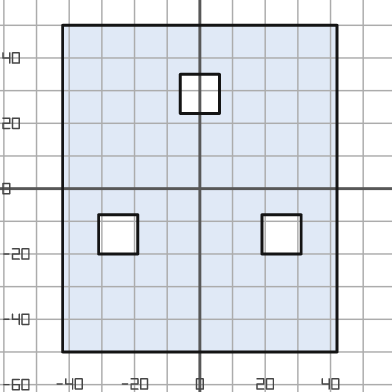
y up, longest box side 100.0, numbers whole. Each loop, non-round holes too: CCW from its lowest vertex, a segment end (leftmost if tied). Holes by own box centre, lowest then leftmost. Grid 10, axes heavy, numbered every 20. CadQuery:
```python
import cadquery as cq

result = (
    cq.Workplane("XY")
    .moveTo(-42.0, -50.0)
    .lineTo(42.0, -50.0)
    .lineTo(42.0, 50.0)
    .lineTo(-42.0, 50.0)
    .close()
    .moveTo(-31.0, -20.0)
    .lineTo(-19.0, -20.0)
    .lineTo(-19.0, -8.0)
    .lineTo(-31.0, -8.0)
    .close()
    .moveTo(19.0, -20.0)
    .lineTo(31.0, -20.0)
    .lineTo(31.0, -8.0)
    .lineTo(19.0, -8.0)
    .close()
    .moveTo(-6.0, 23.0)
    .lineTo(6.0, 23.0)
    .lineTo(6.0, 35.0)
    .lineTo(-6.0, 35.0)
    .close()
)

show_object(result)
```